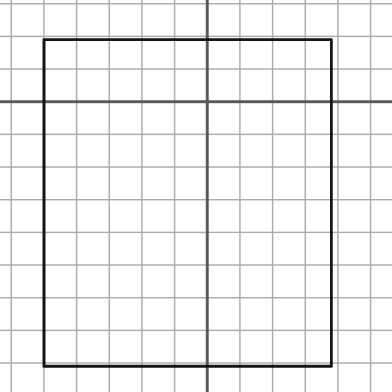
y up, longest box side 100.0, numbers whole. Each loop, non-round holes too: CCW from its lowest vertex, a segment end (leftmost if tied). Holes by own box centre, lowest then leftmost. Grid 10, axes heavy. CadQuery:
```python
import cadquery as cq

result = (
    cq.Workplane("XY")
    .moveTo(-50.0, -81.0)
    .lineTo(38.0, -81.0)
    .lineTo(38.0, 19.0)
    .lineTo(-50.0, 19.0)
    .close()
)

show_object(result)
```